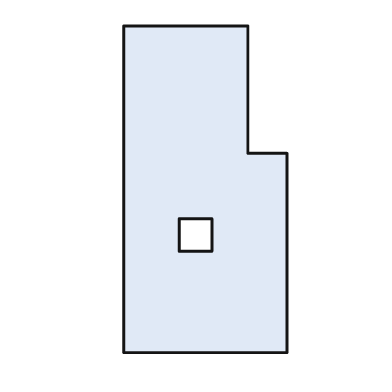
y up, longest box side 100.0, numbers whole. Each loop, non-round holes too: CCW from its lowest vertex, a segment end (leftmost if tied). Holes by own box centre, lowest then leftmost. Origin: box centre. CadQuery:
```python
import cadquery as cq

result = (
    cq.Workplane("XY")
    .moveTo(-25.0, -50.0)
    .lineTo(25.0, -50.0)
    .lineTo(25.0, 11.0)
    .lineTo(13.0, 11.0)
    .lineTo(13.0, 50.0)
    .lineTo(-25.0, 50.0)
    .close()
    .moveTo(-8.0, -19.0)
    .lineTo(2.0, -19.0)
    .lineTo(2.0, -9.0)
    .lineTo(-8.0, -9.0)
    .close()
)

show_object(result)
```